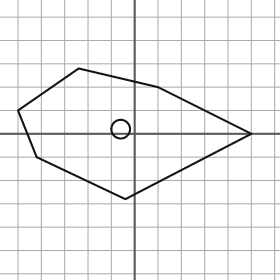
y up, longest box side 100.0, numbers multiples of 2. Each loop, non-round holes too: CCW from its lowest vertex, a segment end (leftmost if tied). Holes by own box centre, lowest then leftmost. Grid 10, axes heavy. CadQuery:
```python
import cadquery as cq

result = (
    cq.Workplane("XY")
    .moveTo(-4.0, -28.0)
    .lineTo(50.0, 0.0)
    .lineTo(10.0, 20.0)
    .lineTo(-24.0, 28.0)
    .lineTo(-50.0, 10.0)
    .lineTo(-42.0, -10.0)
    .close()
    .moveTo(-6.0, 2.0)
    .circle(4.0)
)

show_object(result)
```